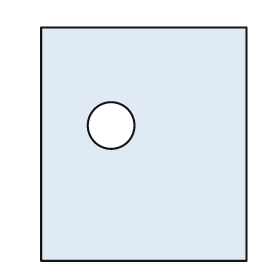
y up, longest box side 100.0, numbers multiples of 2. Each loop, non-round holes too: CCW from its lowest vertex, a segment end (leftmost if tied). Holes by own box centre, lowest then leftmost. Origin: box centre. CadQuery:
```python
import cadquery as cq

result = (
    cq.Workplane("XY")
    .moveTo(-44.0, -50.0)
    .lineTo(44.0, -50.0)
    .lineTo(44.0, 50.0)
    .lineTo(-44.0, 50.0)
    .close()
    .moveTo(-14.0, 8.0)
    .circle(10.0)
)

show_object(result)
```